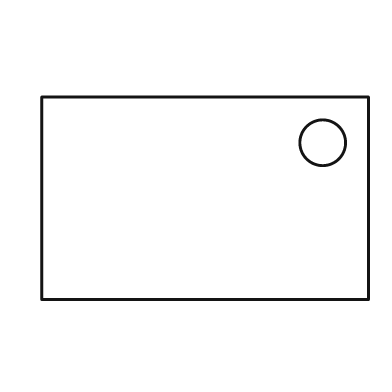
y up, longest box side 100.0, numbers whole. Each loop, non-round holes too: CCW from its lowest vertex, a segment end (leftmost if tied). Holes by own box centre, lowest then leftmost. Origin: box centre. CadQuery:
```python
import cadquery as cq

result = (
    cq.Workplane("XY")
    .moveTo(-50.0, -31.0)
    .lineTo(50.0, -31.0)
    .lineTo(50.0, 31.0)
    .lineTo(-50.0, 31.0)
    .close()
    .moveTo(36.0, 17.0)
    .circle(7.0)
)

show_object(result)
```